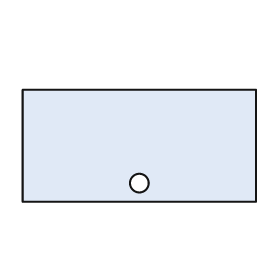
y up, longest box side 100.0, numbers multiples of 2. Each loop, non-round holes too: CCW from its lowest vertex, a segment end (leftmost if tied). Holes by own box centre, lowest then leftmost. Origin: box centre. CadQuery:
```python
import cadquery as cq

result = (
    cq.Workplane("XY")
    .moveTo(-50.0, -24.0)
    .lineTo(50.0, -24.0)
    .lineTo(50.0, 24.0)
    .lineTo(-50.0, 24.0)
    .close()
    .moveTo(0.0, -16.0)
    .circle(4.0)
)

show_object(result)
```